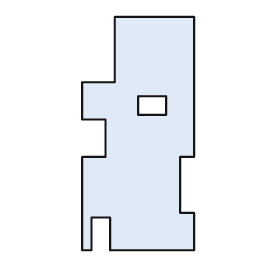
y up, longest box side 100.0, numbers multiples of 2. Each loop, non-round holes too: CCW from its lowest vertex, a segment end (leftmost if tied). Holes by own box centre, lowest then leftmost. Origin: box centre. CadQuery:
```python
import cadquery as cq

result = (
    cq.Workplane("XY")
    .moveTo(-24.0, -50.0)
    .lineTo(-20.0, -50.0)
    .lineTo(-20.0, -36.0)
    .lineTo(-12.0, -36.0)
    .lineTo(-12.0, -50.0)
    .lineTo(24.0, -50.0)
    .lineTo(24.0, -34.0)
    .lineTo(18.0, -34.0)
    .lineTo(18.0, -10.0)
    .lineTo(24.0, -10.0)
    .lineTo(24.0, 50.0)
    .lineTo(-10.0, 50.0)
    .lineTo(-10.0, 22.0)
    .lineTo(-24.0, 22.0)
    .lineTo(-24.0, 6.0)
    .lineTo(-14.0, 6.0)
    .lineTo(-14.0, -10.0)
    .lineTo(-24.0, -10.0)
    .close()
    .moveTo(0.0, 8.0)
    .lineTo(12.0, 8.0)
    .lineTo(12.0, 16.0)
    .lineTo(0.0, 16.0)
    .close()
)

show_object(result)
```